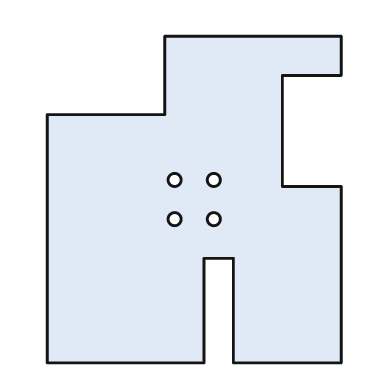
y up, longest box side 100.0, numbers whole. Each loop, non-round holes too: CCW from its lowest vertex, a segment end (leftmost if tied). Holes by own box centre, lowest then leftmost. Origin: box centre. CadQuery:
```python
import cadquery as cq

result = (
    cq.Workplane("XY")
    .moveTo(-45.0, -50.0)
    .lineTo(3.0, -50.0)
    .lineTo(3.0, -18.0)
    .lineTo(12.0, -18.0)
    .lineTo(12.0, -50.0)
    .lineTo(45.0, -50.0)
    .lineTo(45.0, 4.0)
    .lineTo(27.0, 4.0)
    .lineTo(27.0, 38.0)
    .lineTo(45.0, 38.0)
    .lineTo(45.0, 50.0)
    .lineTo(-9.0, 50.0)
    .lineTo(-9.0, 26.0)
    .lineTo(-45.0, 26.0)
    .close()
    .moveTo(-6.0, -6.0)
    .circle(2.0)
    .moveTo(6.0, -6.0)
    .circle(2.0)
    .moveTo(-6.0, 6.0)
    .circle(2.0)
    .moveTo(6.0, 6.0)
    .circle(2.0)
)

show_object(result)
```